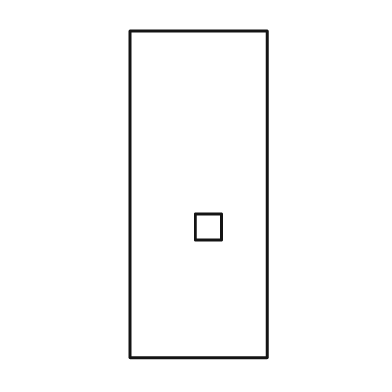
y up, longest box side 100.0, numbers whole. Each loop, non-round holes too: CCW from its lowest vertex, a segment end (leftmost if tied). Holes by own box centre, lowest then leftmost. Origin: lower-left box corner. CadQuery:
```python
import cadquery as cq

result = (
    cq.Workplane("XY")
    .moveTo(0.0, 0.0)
    .lineTo(42.0, 0.0)
    .lineTo(42.0, 100.0)
    .lineTo(0.0, 100.0)
    .close()
    .moveTo(20.0, 36.0)
    .lineTo(28.0, 36.0)
    .lineTo(28.0, 44.0)
    .lineTo(20.0, 44.0)
    .close()
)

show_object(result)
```